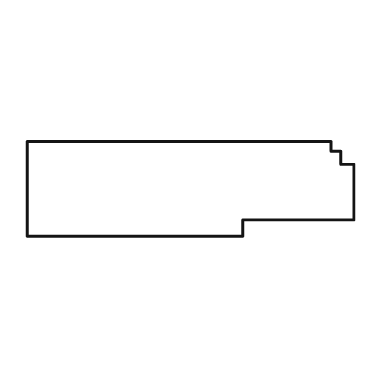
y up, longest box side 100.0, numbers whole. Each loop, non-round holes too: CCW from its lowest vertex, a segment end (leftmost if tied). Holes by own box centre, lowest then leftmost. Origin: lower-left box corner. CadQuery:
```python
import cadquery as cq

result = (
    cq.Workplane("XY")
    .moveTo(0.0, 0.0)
    .lineTo(66.0, 0.0)
    .lineTo(66.0, 5.0)
    .lineTo(100.0, 5.0)
    .lineTo(100.0, 22.0)
    .lineTo(96.0, 22.0)
    .lineTo(96.0, 26.0)
    .lineTo(93.0, 26.0)
    .lineTo(93.0, 29.0)
    .lineTo(0.0, 29.0)
    .close()
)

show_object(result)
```